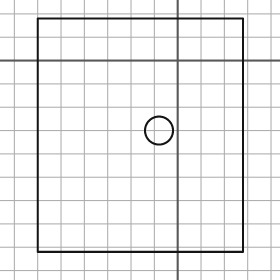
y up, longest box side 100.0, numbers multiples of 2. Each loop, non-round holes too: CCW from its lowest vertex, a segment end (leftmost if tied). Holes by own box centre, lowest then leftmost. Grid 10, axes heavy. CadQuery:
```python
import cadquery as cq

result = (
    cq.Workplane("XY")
    .moveTo(-60.0, -82.0)
    .lineTo(28.0, -82.0)
    .lineTo(28.0, 18.0)
    .lineTo(-60.0, 18.0)
    .close()
    .moveTo(-8.0, -30.0)
    .circle(6.0)
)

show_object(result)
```